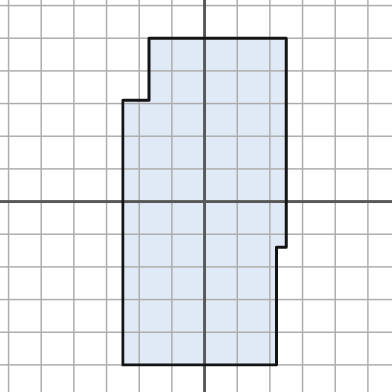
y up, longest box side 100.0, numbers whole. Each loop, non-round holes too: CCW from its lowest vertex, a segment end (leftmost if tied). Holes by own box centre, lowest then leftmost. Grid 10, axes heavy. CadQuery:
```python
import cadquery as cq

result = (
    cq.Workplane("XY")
    .moveTo(-25.0, -50.0)
    .lineTo(22.0, -50.0)
    .lineTo(22.0, -14.0)
    .lineTo(25.0, -14.0)
    .lineTo(25.0, 50.0)
    .lineTo(-17.0, 50.0)
    .lineTo(-17.0, 31.0)
    .lineTo(-25.0, 31.0)
    .close()
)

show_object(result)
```